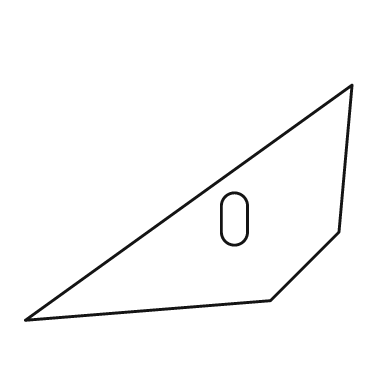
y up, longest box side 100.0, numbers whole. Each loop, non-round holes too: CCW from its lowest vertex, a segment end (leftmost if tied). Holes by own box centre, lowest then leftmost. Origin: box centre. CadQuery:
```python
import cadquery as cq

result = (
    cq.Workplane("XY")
    .moveTo(-50.0, -36.0)
    .lineTo(25.0, -30.0)
    .lineTo(46.0, -9.0)
    .lineTo(50.0, 36.0)
    .close()
    .moveTo(10.0, -9.0)
    .threePointArc((14.0, -13.0), (18.0, -9.0))
    .lineTo(18.0, -1.0)
    .threePointArc((14.0, 3.0), (10.0, -1.0))
    .close()
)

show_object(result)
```